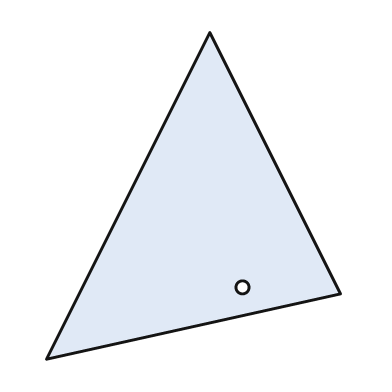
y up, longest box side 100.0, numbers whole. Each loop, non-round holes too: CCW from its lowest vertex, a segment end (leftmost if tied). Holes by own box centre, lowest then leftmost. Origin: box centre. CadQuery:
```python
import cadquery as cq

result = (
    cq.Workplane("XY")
    .moveTo(-45.0, -50.0)
    .lineTo(45.0, -30.0)
    .lineTo(5.0, 50.0)
    .close()
    .moveTo(15.0, -28.0)
    .circle(2.0)
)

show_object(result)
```